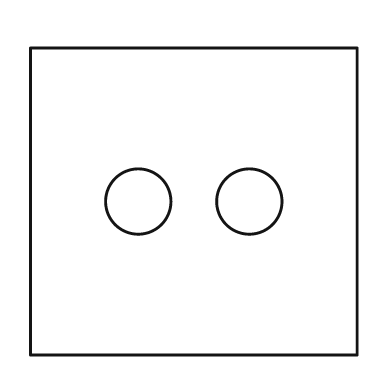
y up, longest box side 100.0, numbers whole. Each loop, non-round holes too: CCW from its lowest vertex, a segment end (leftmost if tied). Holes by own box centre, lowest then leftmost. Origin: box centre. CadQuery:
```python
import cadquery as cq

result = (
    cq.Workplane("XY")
    .moveTo(-50.0, -47.0)
    .lineTo(50.0, -47.0)
    .lineTo(50.0, 47.0)
    .lineTo(-50.0, 47.0)
    .close()
    .moveTo(-17.0, 0.0)
    .circle(10.0)
    .moveTo(17.0, 0.0)
    .circle(10.0)
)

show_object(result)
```